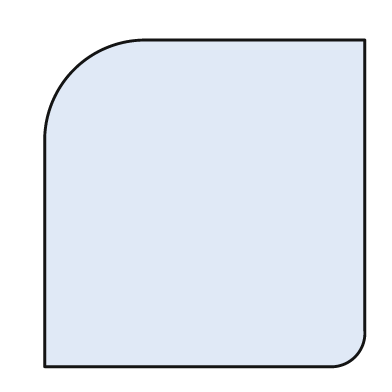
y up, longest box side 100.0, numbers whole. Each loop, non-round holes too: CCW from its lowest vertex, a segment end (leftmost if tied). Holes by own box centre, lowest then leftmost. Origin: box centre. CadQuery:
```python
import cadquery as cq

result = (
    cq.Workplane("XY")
    .moveTo(-49.0, -50.0)
    .lineTo(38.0, -50.0)
    .threePointArc((46.0, -47.0), (49.0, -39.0))
    .lineTo(49.0, 50.0)
    .lineTo(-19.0, 50.0)
    .threePointArc((-40.0, 41.0), (-49.0, 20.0))
    .close()
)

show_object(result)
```